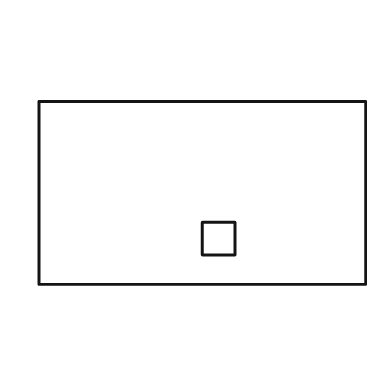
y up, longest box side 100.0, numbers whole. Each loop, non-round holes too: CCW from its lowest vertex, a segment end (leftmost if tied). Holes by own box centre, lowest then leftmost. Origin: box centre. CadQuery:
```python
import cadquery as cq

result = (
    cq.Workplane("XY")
    .moveTo(-50.0, -28.0)
    .lineTo(50.0, -28.0)
    .lineTo(50.0, 28.0)
    .lineTo(-50.0, 28.0)
    .close()
    .moveTo(0.0, -19.0)
    .lineTo(10.0, -19.0)
    .lineTo(10.0, -9.0)
    .lineTo(0.0, -9.0)
    .close()
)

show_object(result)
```